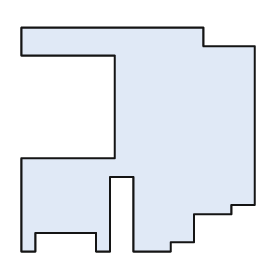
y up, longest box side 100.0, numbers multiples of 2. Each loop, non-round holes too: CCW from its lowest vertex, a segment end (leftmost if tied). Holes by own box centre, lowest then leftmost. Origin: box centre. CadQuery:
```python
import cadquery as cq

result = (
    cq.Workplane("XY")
    .moveTo(-50.0, -48.0)
    .lineTo(-44.0, -48.0)
    .lineTo(-44.0, -40.0)
    .lineTo(-18.0, -40.0)
    .lineTo(-18.0, -48.0)
    .lineTo(-12.0, -48.0)
    .lineTo(-12.0, -16.0)
    .lineTo(-2.0, -16.0)
    .lineTo(-2.0, -48.0)
    .lineTo(14.0, -48.0)
    .lineTo(14.0, -44.0)
    .lineTo(24.0, -44.0)
    .lineTo(24.0, -32.0)
    .lineTo(40.0, -32.0)
    .lineTo(40.0, -28.0)
    .lineTo(50.0, -28.0)
    .lineTo(50.0, 40.0)
    .lineTo(28.0, 40.0)
    .lineTo(28.0, 48.0)
    .lineTo(-50.0, 48.0)
    .lineTo(-50.0, 36.0)
    .lineTo(-10.0, 36.0)
    .lineTo(-10.0, -8.0)
    .lineTo(-50.0, -8.0)
    .close()
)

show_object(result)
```